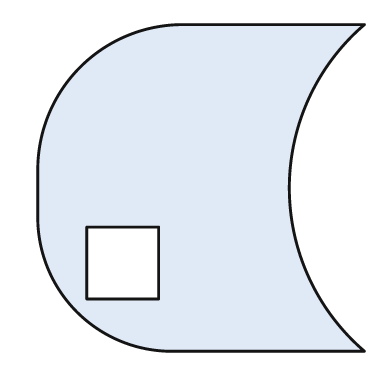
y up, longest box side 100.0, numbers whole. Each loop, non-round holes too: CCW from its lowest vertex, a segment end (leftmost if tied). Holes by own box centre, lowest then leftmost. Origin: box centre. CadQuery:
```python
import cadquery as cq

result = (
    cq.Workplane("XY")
    .moveTo(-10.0, -50.0)
    .lineTo(50.0, -50.0)
    .threePointArc((27.0, 0.0), (50.0, 50.0))
    .lineTo(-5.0, 50.0)
    .threePointArc((-37.0, 37.0), (-50.0, 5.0))
    .lineTo(-50.0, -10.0)
    .threePointArc((-38.0, -38.0), (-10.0, -50.0))
    .close()
    .moveTo(-35.0, -34.0)
    .lineTo(-13.0, -34.0)
    .lineTo(-13.0, -12.0)
    .lineTo(-35.0, -12.0)
    .close()
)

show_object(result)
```